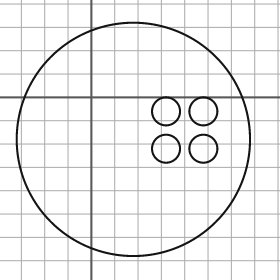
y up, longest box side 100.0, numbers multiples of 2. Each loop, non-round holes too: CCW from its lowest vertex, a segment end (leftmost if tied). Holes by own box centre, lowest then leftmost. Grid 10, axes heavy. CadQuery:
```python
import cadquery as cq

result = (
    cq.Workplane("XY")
    .moveTo(18.0, -18.0)
    .circle(50.0)
    .moveTo(32.0, -22.0)
    .circle(6.0)
    .moveTo(48.0, -22.0)
    .circle(6.0)
    .moveTo(32.0, -6.0)
    .circle(6.0)
    .moveTo(48.0, -6.0)
    .circle(6.0)
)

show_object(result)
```